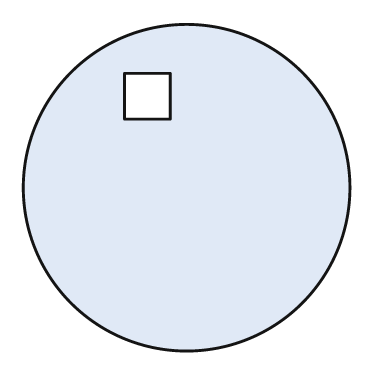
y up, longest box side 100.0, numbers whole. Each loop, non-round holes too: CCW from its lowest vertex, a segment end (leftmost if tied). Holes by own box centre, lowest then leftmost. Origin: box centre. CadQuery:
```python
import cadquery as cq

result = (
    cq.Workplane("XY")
    .moveTo(0.0, 0.0)
    .circle(50.0)
    .moveTo(-19.0, 21.0)
    .lineTo(-5.0, 21.0)
    .lineTo(-5.0, 35.0)
    .lineTo(-19.0, 35.0)
    .close()
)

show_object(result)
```